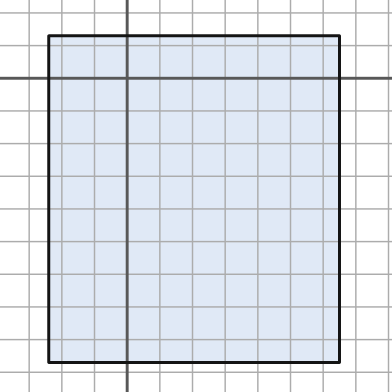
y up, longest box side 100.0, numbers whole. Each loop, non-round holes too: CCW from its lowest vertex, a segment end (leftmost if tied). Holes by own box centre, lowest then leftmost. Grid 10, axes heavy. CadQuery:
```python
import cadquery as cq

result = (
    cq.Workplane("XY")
    .moveTo(-24.0, -87.0)
    .lineTo(65.0, -87.0)
    .lineTo(65.0, 13.0)
    .lineTo(-24.0, 13.0)
    .close()
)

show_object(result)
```